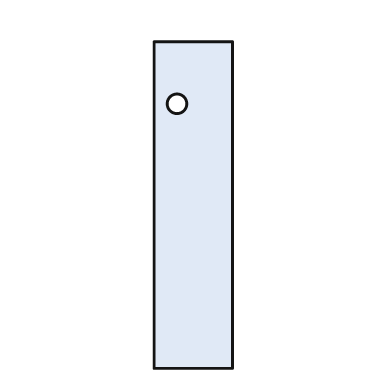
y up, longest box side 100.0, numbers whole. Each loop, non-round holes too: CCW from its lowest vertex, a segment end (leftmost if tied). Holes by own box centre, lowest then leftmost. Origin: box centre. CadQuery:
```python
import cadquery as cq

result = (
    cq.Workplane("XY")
    .moveTo(-12.0, -50.0)
    .lineTo(12.0, -50.0)
    .lineTo(12.0, 50.0)
    .lineTo(-12.0, 50.0)
    .close()
    .moveTo(-5.0, 31.0)
    .circle(3.0)
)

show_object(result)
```